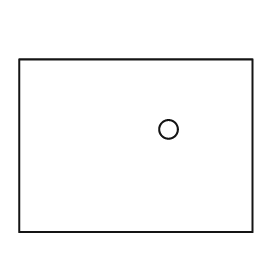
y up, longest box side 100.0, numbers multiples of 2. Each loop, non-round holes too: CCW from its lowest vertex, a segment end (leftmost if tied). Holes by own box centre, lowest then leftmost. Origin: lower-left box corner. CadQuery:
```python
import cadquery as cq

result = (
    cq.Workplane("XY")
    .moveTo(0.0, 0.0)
    .lineTo(100.0, 0.0)
    .lineTo(100.0, 74.0)
    .lineTo(0.0, 74.0)
    .close()
    .moveTo(64.0, 44.0)
    .circle(4.0)
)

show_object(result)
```